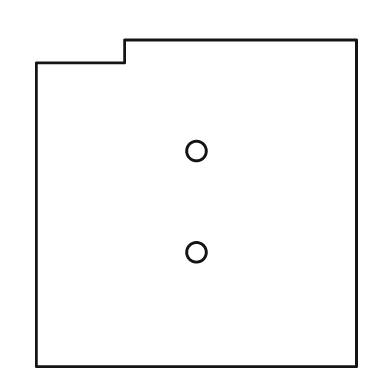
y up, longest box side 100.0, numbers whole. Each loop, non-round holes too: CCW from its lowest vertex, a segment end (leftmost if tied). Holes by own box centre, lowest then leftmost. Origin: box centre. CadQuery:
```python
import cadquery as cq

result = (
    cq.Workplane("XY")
    .moveTo(-49.0, -50.0)
    .lineTo(49.0, -50.0)
    .lineTo(49.0, 50.0)
    .lineTo(-22.0, 50.0)
    .lineTo(-22.0, 43.0)
    .lineTo(-49.0, 43.0)
    .close()
    .moveTo(0.0, -15.0)
    .circle(3.0)
    .moveTo(0.0, 16.0)
    .circle(3.0)
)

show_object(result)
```